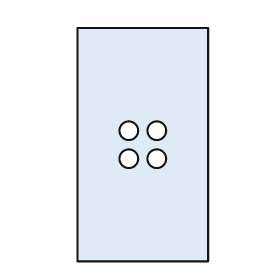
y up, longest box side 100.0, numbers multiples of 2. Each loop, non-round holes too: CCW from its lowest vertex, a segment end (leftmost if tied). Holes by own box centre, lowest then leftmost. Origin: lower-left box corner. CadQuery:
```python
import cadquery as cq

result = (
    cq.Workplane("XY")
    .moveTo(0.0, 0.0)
    .lineTo(56.0, 0.0)
    .lineTo(56.0, 100.0)
    .lineTo(0.0, 100.0)
    .close()
    .moveTo(22.0, 44.0)
    .circle(4.0)
    .moveTo(34.0, 44.0)
    .circle(4.0)
    .moveTo(22.0, 56.0)
    .circle(4.0)
    .moveTo(34.0, 56.0)
    .circle(4.0)
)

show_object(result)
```